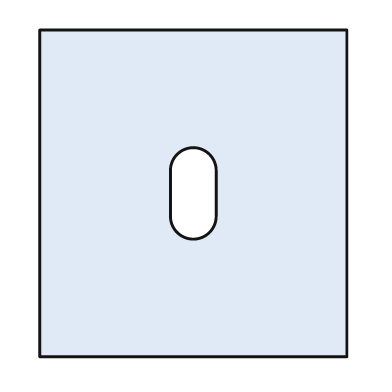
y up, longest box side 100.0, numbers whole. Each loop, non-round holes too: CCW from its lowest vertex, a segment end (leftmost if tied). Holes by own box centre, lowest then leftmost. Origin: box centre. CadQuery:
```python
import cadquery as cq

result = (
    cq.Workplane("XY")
    .moveTo(-47.0, -50.0)
    .lineTo(47.0, -50.0)
    .lineTo(47.0, 50.0)
    .lineTo(-47.0, 50.0)
    .close()
    .moveTo(-7.0, -7.0)
    .threePointArc((0.0, -14.0), (7.0, -7.0))
    .lineTo(7.0, 7.0)
    .threePointArc((0.0, 14.0), (-7.0, 7.0))
    .close()
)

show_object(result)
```